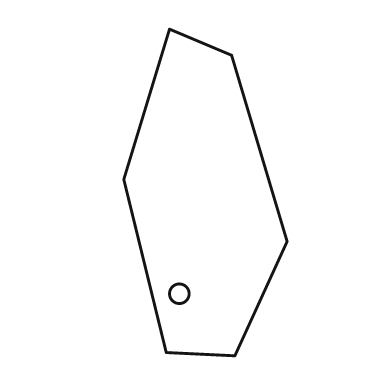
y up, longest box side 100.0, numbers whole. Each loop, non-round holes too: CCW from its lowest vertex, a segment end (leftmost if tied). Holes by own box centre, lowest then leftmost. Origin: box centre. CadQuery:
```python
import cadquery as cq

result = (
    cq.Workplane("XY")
    .moveTo(9.0, -50.0)
    .lineTo(25.0, -15.0)
    .lineTo(8.0, 42.0)
    .lineTo(-11.0, 50.0)
    .lineTo(-25.0, 4.0)
    .lineTo(-12.0, -49.0)
    .close()
    .moveTo(-8.0, -31.0)
    .circle(3.0)
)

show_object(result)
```